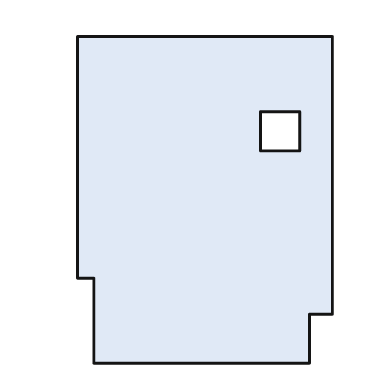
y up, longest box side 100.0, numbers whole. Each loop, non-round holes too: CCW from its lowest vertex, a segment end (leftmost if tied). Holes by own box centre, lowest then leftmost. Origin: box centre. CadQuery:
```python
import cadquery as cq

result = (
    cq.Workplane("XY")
    .moveTo(-34.0, -50.0)
    .lineTo(32.0, -50.0)
    .lineTo(32.0, -35.0)
    .lineTo(39.0, -35.0)
    .lineTo(39.0, 50.0)
    .lineTo(-39.0, 50.0)
    .lineTo(-39.0, -24.0)
    .lineTo(-34.0, -24.0)
    .close()
    .moveTo(17.0, 15.0)
    .lineTo(29.0, 15.0)
    .lineTo(29.0, 27.0)
    .lineTo(17.0, 27.0)
    .close()
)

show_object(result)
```